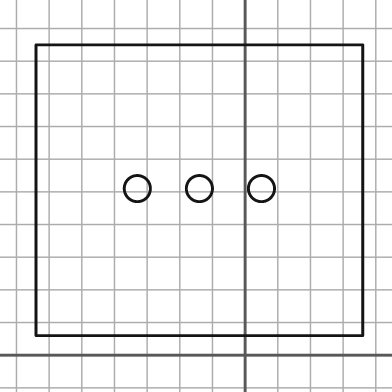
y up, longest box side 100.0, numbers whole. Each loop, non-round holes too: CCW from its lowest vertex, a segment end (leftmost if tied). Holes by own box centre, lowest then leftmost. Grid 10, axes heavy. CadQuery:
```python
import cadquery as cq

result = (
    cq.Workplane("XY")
    .moveTo(-64.0, 6.0)
    .lineTo(36.0, 6.0)
    .lineTo(36.0, 95.0)
    .lineTo(-64.0, 95.0)
    .close()
    .moveTo(-33.0, 51.0)
    .circle(4.0)
    .moveTo(-14.0, 51.0)
    .circle(4.0)
    .moveTo(5.0, 51.0)
    .circle(4.0)
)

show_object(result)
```